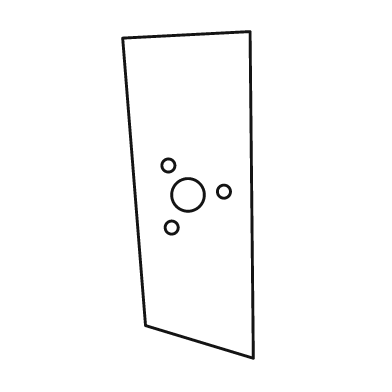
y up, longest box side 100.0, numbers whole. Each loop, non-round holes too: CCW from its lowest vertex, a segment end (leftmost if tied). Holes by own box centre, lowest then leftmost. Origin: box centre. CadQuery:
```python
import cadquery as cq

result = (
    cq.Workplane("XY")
    .moveTo(20.0, -50.0)
    .lineTo(19.0, 50.0)
    .lineTo(-20.0, 48.0)
    .lineTo(-13.0, -40.0)
    .close()
    .moveTo(-5.0, -10.0)
    .circle(2.0)
    .moveTo(0.0, 0.0)
    .circle(5.0)
    .moveTo(11.0, 1.0)
    .circle(2.0)
    .moveTo(-6.0, 9.0)
    .circle(2.0)
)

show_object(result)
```